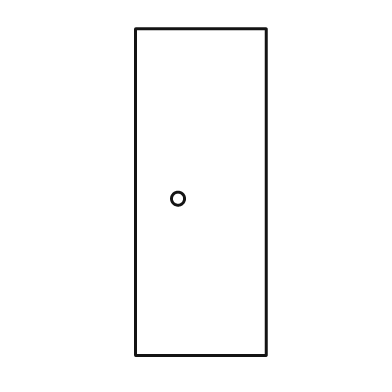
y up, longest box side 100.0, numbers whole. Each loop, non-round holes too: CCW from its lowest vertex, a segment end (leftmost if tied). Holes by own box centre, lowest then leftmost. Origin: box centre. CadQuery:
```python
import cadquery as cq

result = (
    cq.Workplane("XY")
    .moveTo(-20.0, -50.0)
    .lineTo(20.0, -50.0)
    .lineTo(20.0, 50.0)
    .lineTo(-20.0, 50.0)
    .close()
    .moveTo(-7.0, -2.0)
    .circle(2.0)
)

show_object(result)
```